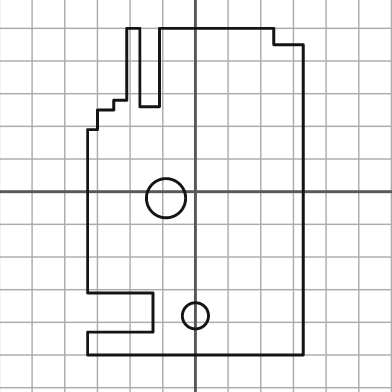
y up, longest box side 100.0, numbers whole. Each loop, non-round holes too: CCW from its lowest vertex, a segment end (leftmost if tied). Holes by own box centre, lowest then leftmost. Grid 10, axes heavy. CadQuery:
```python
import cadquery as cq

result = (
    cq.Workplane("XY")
    .moveTo(-33.0, -50.0)
    .lineTo(33.0, -50.0)
    .lineTo(33.0, 45.0)
    .lineTo(24.0, 45.0)
    .lineTo(24.0, 50.0)
    .lineTo(-11.0, 50.0)
    .lineTo(-11.0, 26.0)
    .lineTo(-17.0, 26.0)
    .lineTo(-17.0, 50.0)
    .lineTo(-21.0, 50.0)
    .lineTo(-21.0, 28.0)
    .lineTo(-25.0, 28.0)
    .lineTo(-25.0, 25.0)
    .lineTo(-30.0, 25.0)
    .lineTo(-30.0, 19.0)
    .lineTo(-33.0, 19.0)
    .lineTo(-33.0, -31.0)
    .lineTo(-13.0, -31.0)
    .lineTo(-13.0, -43.0)
    .lineTo(-33.0, -43.0)
    .close()
    .moveTo(0.0, -38.0)
    .circle(4.0)
    .moveTo(-9.0, -2.0)
    .circle(6.0)
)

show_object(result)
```